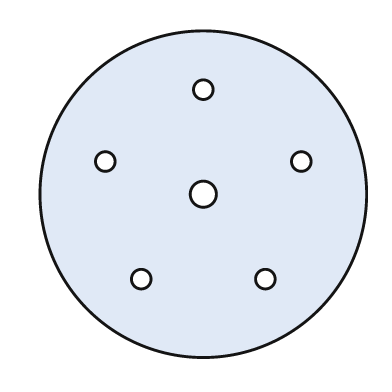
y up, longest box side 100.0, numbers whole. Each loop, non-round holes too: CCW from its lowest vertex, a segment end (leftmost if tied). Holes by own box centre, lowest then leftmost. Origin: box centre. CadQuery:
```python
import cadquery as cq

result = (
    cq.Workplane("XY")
    .moveTo(0.0, 0.0)
    .circle(50.0)
    .moveTo(-19.0, -26.0)
    .circle(3.0)
    .moveTo(19.0, -26.0)
    .circle(3.0)
    .moveTo(0.0, 0.0)
    .circle(4.0)
    .moveTo(-30.0, 10.0)
    .circle(3.0)
    .moveTo(30.0, 10.0)
    .circle(3.0)
    .moveTo(0.0, 32.0)
    .circle(3.0)
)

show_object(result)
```